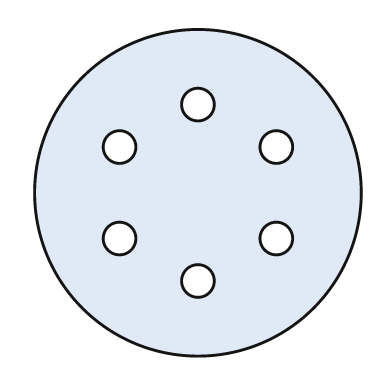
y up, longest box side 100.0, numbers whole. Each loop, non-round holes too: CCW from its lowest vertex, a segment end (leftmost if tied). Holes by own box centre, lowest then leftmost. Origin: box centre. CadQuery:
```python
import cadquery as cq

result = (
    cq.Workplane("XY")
    .moveTo(0.0, 0.0)
    .circle(50.0)
    .moveTo(0.0, -27.0)
    .circle(5.0)
    .moveTo(-24.0, -14.0)
    .circle(5.0)
    .moveTo(24.0, -14.0)
    .circle(5.0)
    .moveTo(-24.0, 14.0)
    .circle(5.0)
    .moveTo(24.0, 14.0)
    .circle(5.0)
    .moveTo(0.0, 27.0)
    .circle(5.0)
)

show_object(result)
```